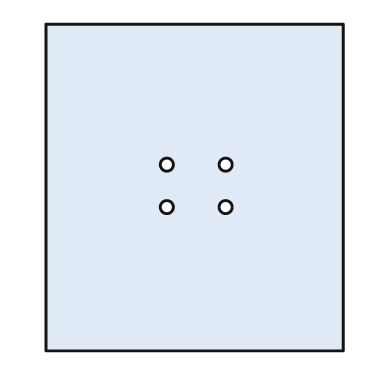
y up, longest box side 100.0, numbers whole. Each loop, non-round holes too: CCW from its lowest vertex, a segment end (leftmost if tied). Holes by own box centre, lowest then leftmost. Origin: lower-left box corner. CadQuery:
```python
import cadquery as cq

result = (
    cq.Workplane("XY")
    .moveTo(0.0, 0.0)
    .lineTo(91.0, 0.0)
    .lineTo(91.0, 100.0)
    .lineTo(0.0, 100.0)
    .close()
    .moveTo(37.0, 44.0)
    .circle(2.0)
    .moveTo(55.0, 44.0)
    .circle(2.0)
    .moveTo(37.0, 57.0)
    .circle(2.0)
    .moveTo(55.0, 57.0)
    .circle(2.0)
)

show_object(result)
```